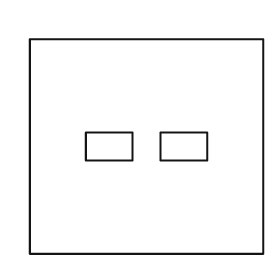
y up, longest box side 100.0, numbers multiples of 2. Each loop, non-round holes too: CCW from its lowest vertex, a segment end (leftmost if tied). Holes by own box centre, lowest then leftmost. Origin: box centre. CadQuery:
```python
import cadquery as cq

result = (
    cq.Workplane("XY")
    .moveTo(-50.0, -46.0)
    .lineTo(50.0, -46.0)
    .lineTo(50.0, 46.0)
    .lineTo(-50.0, 46.0)
    .close()
    .moveTo(-26.0, -6.0)
    .lineTo(-6.0, -6.0)
    .lineTo(-6.0, 6.0)
    .lineTo(-26.0, 6.0)
    .close()
    .moveTo(6.0, -6.0)
    .lineTo(26.0, -6.0)
    .lineTo(26.0, 6.0)
    .lineTo(6.0, 6.0)
    .close()
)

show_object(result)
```